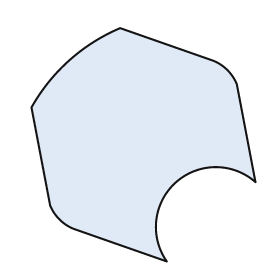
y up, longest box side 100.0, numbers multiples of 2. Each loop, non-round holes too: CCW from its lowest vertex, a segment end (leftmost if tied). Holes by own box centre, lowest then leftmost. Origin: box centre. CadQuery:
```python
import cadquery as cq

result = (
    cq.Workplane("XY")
    .moveTo(10.0, -50.0)
    .threePointArc((14.0, -16.0), (48.0, -16.0))
    .lineTo(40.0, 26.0)
    .threePointArc((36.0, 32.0), (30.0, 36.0))
    .lineTo(-10.0, 50.0)
    .threePointArc((-32.0, 36.0), (-48.0, 16.0))
    .lineTo(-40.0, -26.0)
    .threePointArc((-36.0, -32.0), (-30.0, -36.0))
    .close()
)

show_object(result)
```